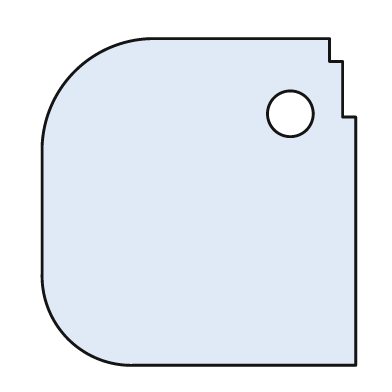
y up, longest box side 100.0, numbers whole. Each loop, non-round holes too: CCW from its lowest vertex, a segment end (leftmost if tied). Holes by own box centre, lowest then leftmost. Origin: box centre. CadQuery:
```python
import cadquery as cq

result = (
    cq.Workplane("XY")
    .moveTo(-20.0, -50.0)
    .lineTo(48.0, -50.0)
    .lineTo(48.0, 26.0)
    .lineTo(44.0, 26.0)
    .lineTo(44.0, 43.0)
    .lineTo(40.0, 43.0)
    .lineTo(40.0, 50.0)
    .lineTo(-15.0, 50.0)
    .threePointArc((-38.0, 40.0), (-48.0, 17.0))
    .lineTo(-48.0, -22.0)
    .threePointArc((-40.0, -42.0), (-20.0, -50.0))
    .close()
    .moveTo(28.0, 27.0)
    .circle(7.0)
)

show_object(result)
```